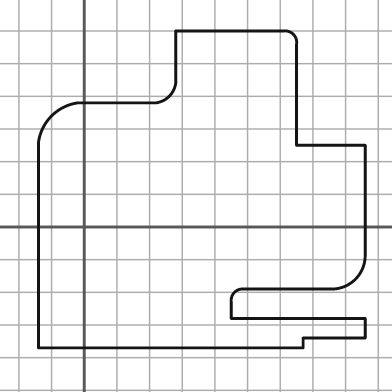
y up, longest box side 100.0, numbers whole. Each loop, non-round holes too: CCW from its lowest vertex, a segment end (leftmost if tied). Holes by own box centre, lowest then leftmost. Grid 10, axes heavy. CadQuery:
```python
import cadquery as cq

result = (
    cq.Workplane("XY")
    .moveTo(-14.0, -37.0)
    .lineTo(67.0, -37.0)
    .lineTo(67.0, -34.0)
    .lineTo(86.0, -34.0)
    .lineTo(86.0, -28.0)
    .lineTo(45.0, -28.0)
    .lineTo(45.0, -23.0)
    .threePointArc((46.0, -20.0), (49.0, -19.0))
    .lineTo(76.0, -19.0)
    .threePointArc((83.0, -16.0), (86.0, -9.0))
    .lineTo(86.0, 25.0)
    .lineTo(65.0, 25.0)
    .lineTo(65.0, 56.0)
    .threePointArc((64.0, 59.0), (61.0, 60.0))
    .lineTo(28.0, 60.0)
    .lineTo(28.0, 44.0)
    .threePointArc((26.0, 40.0), (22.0, 38.0))
    .lineTo(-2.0, 38.0)
    .threePointArc((-10.0, 34.0), (-14.0, 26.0))
    .close()
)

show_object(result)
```